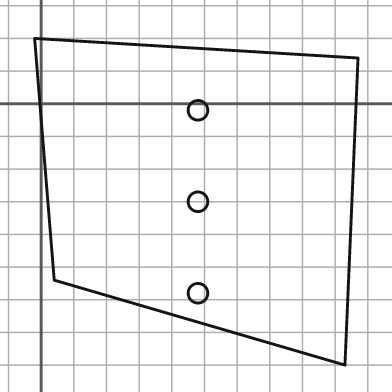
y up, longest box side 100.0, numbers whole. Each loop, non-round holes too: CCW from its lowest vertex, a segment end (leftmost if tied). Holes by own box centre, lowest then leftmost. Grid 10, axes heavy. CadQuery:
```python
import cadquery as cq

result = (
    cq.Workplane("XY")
    .moveTo(93.0, -80.0)
    .lineTo(97.0, 14.0)
    .lineTo(-2.0, 20.0)
    .lineTo(4.0, -54.0)
    .close()
    .moveTo(48.0, -58.0)
    .circle(3.0)
    .moveTo(48.0, -30.0)
    .circle(3.0)
    .moveTo(48.0, -2.0)
    .circle(3.0)
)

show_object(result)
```